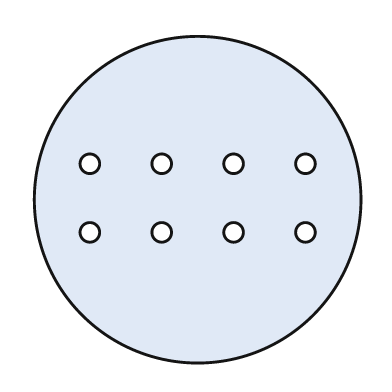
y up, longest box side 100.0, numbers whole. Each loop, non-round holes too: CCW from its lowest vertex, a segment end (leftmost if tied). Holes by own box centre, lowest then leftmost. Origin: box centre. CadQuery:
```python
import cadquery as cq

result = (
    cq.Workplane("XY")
    .moveTo(0.0, 0.0)
    .circle(50.0)
    .moveTo(-33.0, -10.0)
    .circle(3.0)
    .moveTo(-11.0, -10.0)
    .circle(3.0)
    .moveTo(11.0, -10.0)
    .circle(3.0)
    .moveTo(33.0, -10.0)
    .circle(3.0)
    .moveTo(-33.0, 11.0)
    .circle(3.0)
    .moveTo(-11.0, 11.0)
    .circle(3.0)
    .moveTo(11.0, 11.0)
    .circle(3.0)
    .moveTo(33.0, 11.0)
    .circle(3.0)
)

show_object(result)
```